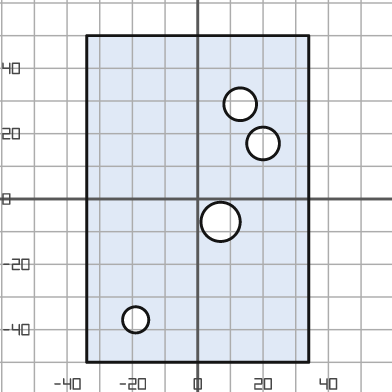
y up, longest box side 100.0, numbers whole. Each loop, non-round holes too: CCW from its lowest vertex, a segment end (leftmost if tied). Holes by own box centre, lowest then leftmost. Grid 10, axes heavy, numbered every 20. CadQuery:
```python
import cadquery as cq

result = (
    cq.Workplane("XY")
    .moveTo(-34.0, -50.0)
    .lineTo(34.0, -50.0)
    .lineTo(34.0, 50.0)
    .lineTo(-34.0, 50.0)
    .close()
    .moveTo(-19.0, -37.0)
    .circle(4.0)
    .moveTo(7.0, -7.0)
    .circle(6.0)
    .moveTo(20.0, 17.0)
    .circle(5.0)
    .moveTo(13.0, 29.0)
    .circle(5.0)
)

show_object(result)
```